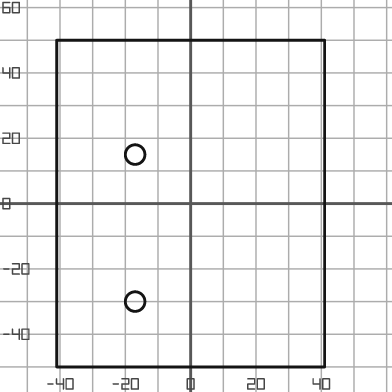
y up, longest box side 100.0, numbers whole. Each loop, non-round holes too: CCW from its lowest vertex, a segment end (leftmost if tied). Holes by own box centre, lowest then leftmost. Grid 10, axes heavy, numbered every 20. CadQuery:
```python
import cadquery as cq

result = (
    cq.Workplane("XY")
    .moveTo(-41.0, -50.0)
    .lineTo(41.0, -50.0)
    .lineTo(41.0, 50.0)
    .lineTo(-41.0, 50.0)
    .close()
    .moveTo(-17.0, -30.0)
    .circle(3.0)
    .moveTo(-17.0, 15.0)
    .circle(3.0)
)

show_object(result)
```